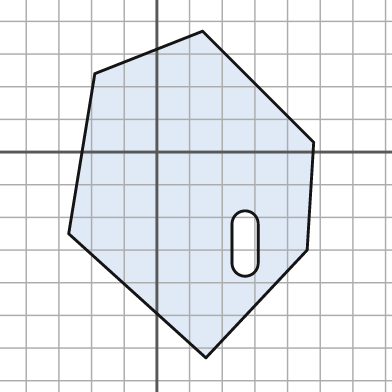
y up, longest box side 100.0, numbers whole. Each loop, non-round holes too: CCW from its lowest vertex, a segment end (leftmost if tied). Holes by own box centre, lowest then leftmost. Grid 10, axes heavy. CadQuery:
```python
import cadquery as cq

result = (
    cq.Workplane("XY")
    .moveTo(15.0, -63.0)
    .lineTo(46.0, -30.0)
    .lineTo(48.0, 3.0)
    .lineTo(14.0, 37.0)
    .lineTo(-19.0, 24.0)
    .lineTo(-27.0, -25.0)
    .close()
    .moveTo(23.0, -34.0)
    .threePointArc((27.0, -38.0), (31.0, -34.0))
    .lineTo(31.0, -22.0)
    .threePointArc((27.0, -18.0), (23.0, -22.0))
    .close()
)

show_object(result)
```